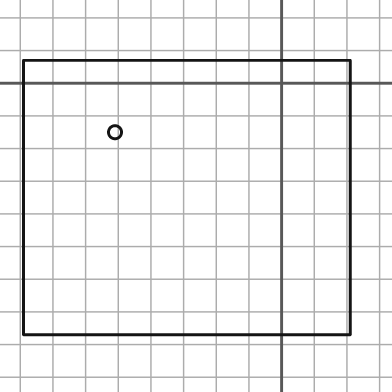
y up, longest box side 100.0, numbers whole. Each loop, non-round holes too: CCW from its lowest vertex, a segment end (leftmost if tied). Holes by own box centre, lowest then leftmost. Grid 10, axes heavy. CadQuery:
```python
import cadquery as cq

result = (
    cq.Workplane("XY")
    .moveTo(-79.0, -77.0)
    .lineTo(21.0, -77.0)
    .lineTo(21.0, 7.0)
    .lineTo(-79.0, 7.0)
    .close()
    .moveTo(-51.0, -15.0)
    .circle(2.0)
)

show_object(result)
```